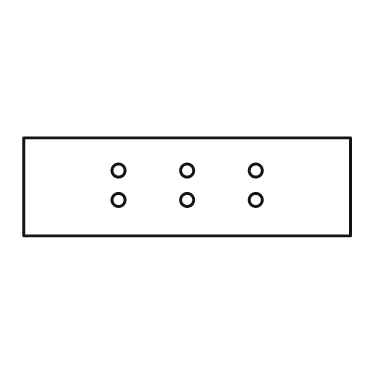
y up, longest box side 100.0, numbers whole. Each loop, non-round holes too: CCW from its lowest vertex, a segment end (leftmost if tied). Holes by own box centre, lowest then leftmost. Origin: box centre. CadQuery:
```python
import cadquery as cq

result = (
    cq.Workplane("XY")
    .moveTo(-50.0, -15.0)
    .lineTo(50.0, -15.0)
    .lineTo(50.0, 15.0)
    .lineTo(-50.0, 15.0)
    .close()
    .moveTo(-21.0, -4.0)
    .circle(2.0)
    .moveTo(0.0, -4.0)
    .circle(2.0)
    .moveTo(21.0, -4.0)
    .circle(2.0)
    .moveTo(-21.0, 5.0)
    .circle(2.0)
    .moveTo(0.0, 5.0)
    .circle(2.0)
    .moveTo(21.0, 5.0)
    .circle(2.0)
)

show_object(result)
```